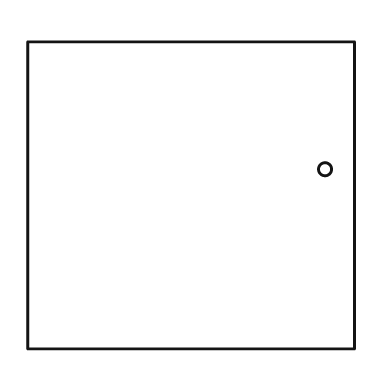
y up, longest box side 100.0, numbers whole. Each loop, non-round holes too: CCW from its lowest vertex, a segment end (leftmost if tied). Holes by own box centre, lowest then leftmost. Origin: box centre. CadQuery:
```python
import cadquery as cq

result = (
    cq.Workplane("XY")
    .moveTo(-50.0, -47.0)
    .lineTo(50.0, -47.0)
    .lineTo(50.0, 47.0)
    .lineTo(-50.0, 47.0)
    .close()
    .moveTo(41.0, 8.0)
    .circle(2.0)
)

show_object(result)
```